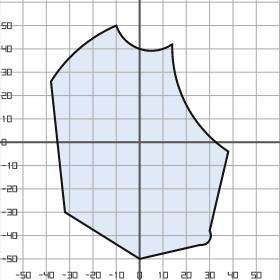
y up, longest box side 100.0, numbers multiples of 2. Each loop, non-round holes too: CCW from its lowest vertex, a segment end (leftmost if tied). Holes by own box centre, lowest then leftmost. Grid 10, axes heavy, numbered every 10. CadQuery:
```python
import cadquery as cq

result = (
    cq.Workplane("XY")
    .moveTo(0.0, -50.0)
    .lineTo(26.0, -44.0)
    .threePointArc((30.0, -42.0), (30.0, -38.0))
    .lineTo(38.0, -4.0)
    .threePointArc((20.0, 16.0), (14.0, 42.0))
    .threePointArc((0.0, 40.0), (-10.0, 50.0))
    .threePointArc((-26.0, 40.0), (-38.0, 26.0))
    .lineTo(-32.0, -30.0)
    .close()
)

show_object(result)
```